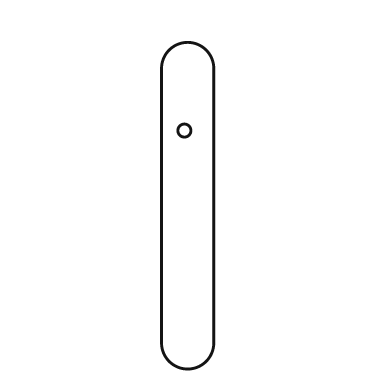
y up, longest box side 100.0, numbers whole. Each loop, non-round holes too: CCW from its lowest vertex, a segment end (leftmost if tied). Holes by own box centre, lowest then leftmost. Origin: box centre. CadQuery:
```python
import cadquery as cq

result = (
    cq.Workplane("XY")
    .moveTo(-8.0, -42.0)
    .threePointArc((0.0, -50.0), (8.0, -42.0))
    .lineTo(8.0, 42.0)
    .threePointArc((0.0, 50.0), (-8.0, 42.0))
    .close()
    .moveTo(-1.0, 23.0)
    .circle(2.0)
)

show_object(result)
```